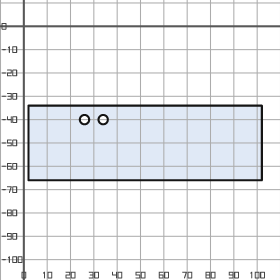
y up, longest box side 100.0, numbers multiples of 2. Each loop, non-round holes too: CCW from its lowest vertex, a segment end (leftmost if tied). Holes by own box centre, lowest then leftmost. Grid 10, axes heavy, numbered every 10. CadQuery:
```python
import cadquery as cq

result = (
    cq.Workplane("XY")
    .moveTo(2.0, -66.0)
    .lineTo(102.0, -66.0)
    .lineTo(102.0, -34.0)
    .lineTo(2.0, -34.0)
    .close()
    .moveTo(26.0, -40.0)
    .circle(2.0)
    .moveTo(34.0, -40.0)
    .circle(2.0)
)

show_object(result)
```